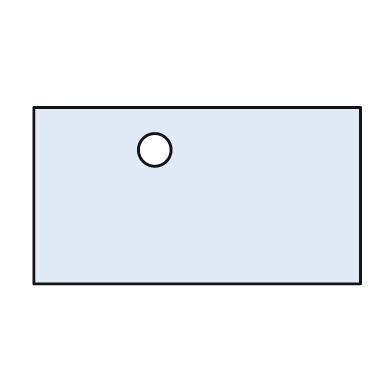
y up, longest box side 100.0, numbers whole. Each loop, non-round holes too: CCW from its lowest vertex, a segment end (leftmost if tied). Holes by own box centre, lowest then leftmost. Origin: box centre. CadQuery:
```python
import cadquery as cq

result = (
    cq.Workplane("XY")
    .moveTo(-50.0, -27.0)
    .lineTo(50.0, -27.0)
    .lineTo(50.0, 27.0)
    .lineTo(-50.0, 27.0)
    .close()
    .moveTo(-13.0, 14.0)
    .circle(5.0)
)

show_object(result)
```